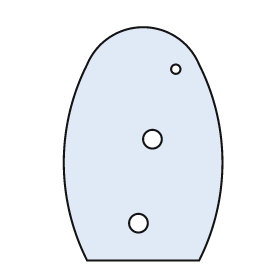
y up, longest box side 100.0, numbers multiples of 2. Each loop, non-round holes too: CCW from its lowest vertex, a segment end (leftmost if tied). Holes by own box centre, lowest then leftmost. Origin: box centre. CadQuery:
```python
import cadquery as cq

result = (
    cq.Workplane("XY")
    .moveTo(-24.0, -50.0)
    .lineTo(24.0, -50.0)
    .threePointArc((34.0, -8.0), (24.0, 34.0))
    .threePointArc((0.0, 50.0), (-24.0, 34.0))
    .threePointArc((-34.0, -8.0), (-24.0, -50.0))
    .close()
    .moveTo(-2.0, -34.0)
    .circle(4.0)
    .moveTo(4.0, 2.0)
    .circle(4.0)
    .moveTo(14.0, 32.0)
    .circle(2.0)
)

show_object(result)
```